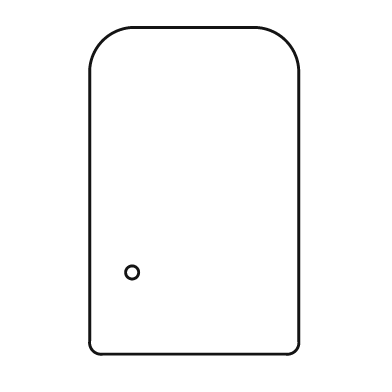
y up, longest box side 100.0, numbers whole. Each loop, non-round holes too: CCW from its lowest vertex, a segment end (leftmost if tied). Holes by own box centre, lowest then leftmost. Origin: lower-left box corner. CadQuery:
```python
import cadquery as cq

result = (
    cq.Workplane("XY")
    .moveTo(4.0, 0.0)
    .lineTo(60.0, 0.0)
    .threePointArc((63.0, 1.0), (64.0, 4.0))
    .lineTo(64.0, 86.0)
    .threePointArc((60.0, 96.0), (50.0, 100.0))
    .lineTo(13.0, 100.0)
    .threePointArc((4.0, 96.0), (0.0, 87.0))
    .lineTo(0.0, 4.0)
    .threePointArc((1.0, 1.0), (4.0, 0.0))
    .close()
    .moveTo(13.0, 25.0)
    .circle(2.0)
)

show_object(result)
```